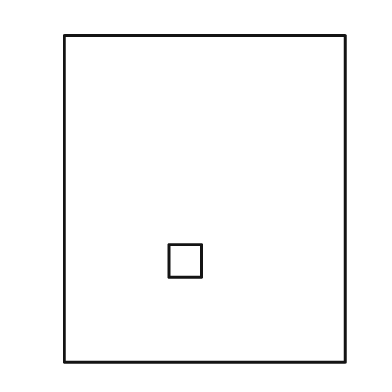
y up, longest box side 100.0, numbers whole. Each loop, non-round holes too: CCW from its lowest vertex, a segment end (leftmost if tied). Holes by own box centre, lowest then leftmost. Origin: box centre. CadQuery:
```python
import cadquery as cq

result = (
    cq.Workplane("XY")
    .moveTo(-43.0, -50.0)
    .lineTo(43.0, -50.0)
    .lineTo(43.0, 50.0)
    .lineTo(-43.0, 50.0)
    .close()
    .moveTo(-11.0, -24.0)
    .lineTo(-1.0, -24.0)
    .lineTo(-1.0, -14.0)
    .lineTo(-11.0, -14.0)
    .close()
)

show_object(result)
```